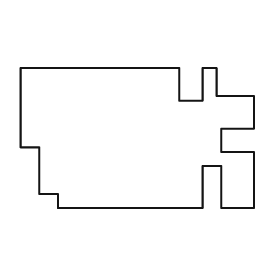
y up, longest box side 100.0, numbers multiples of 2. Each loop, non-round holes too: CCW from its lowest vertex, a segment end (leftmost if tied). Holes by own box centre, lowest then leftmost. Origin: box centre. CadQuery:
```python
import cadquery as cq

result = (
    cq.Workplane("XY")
    .moveTo(-34.0, -30.0)
    .lineTo(28.0, -30.0)
    .lineTo(28.0, -12.0)
    .lineTo(36.0, -12.0)
    .lineTo(36.0, -30.0)
    .lineTo(50.0, -30.0)
    .lineTo(50.0, -6.0)
    .lineTo(36.0, -6.0)
    .lineTo(36.0, 4.0)
    .lineTo(50.0, 4.0)
    .lineTo(50.0, 18.0)
    .lineTo(34.0, 18.0)
    .lineTo(34.0, 30.0)
    .lineTo(28.0, 30.0)
    .lineTo(28.0, 16.0)
    .lineTo(18.0, 16.0)
    .lineTo(18.0, 30.0)
    .lineTo(-50.0, 30.0)
    .lineTo(-50.0, -4.0)
    .lineTo(-42.0, -4.0)
    .lineTo(-42.0, -24.0)
    .lineTo(-34.0, -24.0)
    .close()
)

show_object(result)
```